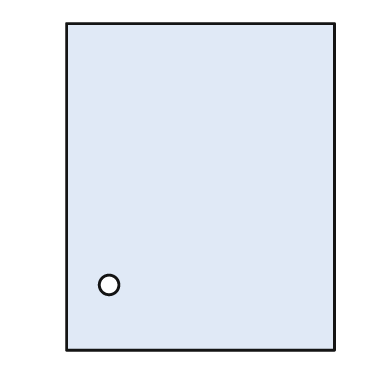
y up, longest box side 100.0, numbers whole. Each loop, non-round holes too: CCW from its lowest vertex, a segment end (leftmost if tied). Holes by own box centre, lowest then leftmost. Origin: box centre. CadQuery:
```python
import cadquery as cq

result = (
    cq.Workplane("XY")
    .moveTo(-41.0, -50.0)
    .lineTo(41.0, -50.0)
    .lineTo(41.0, 50.0)
    .lineTo(-41.0, 50.0)
    .close()
    .moveTo(-28.0, -30.0)
    .circle(3.0)
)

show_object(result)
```